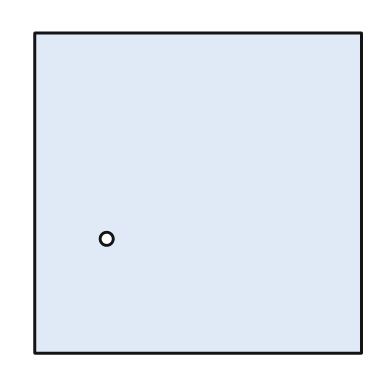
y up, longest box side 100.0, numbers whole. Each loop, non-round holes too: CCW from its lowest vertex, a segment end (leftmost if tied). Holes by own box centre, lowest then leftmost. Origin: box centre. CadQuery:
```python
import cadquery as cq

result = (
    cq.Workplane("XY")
    .moveTo(-50.0, -49.0)
    .lineTo(50.0, -49.0)
    .lineTo(50.0, 49.0)
    .lineTo(-50.0, 49.0)
    .close()
    .moveTo(-28.0, -14.0)
    .circle(2.0)
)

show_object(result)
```